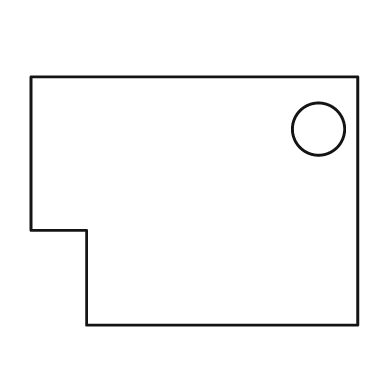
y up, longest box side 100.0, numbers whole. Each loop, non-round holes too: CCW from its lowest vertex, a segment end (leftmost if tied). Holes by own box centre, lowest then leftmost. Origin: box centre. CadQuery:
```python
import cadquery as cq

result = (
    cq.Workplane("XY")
    .moveTo(-33.0, -38.0)
    .lineTo(50.0, -38.0)
    .lineTo(50.0, 38.0)
    .lineTo(-50.0, 38.0)
    .lineTo(-50.0, -9.0)
    .lineTo(-33.0, -9.0)
    .close()
    .moveTo(38.0, 22.0)
    .circle(8.0)
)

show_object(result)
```